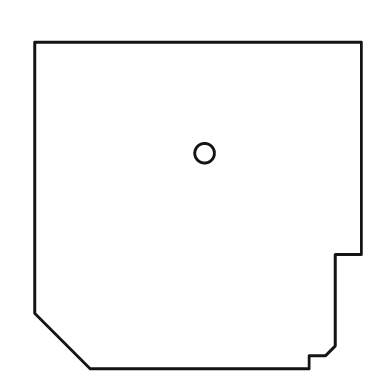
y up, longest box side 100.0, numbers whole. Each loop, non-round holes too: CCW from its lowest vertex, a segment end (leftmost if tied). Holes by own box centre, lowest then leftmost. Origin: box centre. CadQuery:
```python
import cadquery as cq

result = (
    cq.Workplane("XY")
    .moveTo(-33.0, -50.0)
    .lineTo(34.0, -50.0)
    .lineTo(34.0, -46.0)
    .lineTo(39.0, -46.0)
    .lineTo(42.0, -43.0)
    .lineTo(42.0, -15.0)
    .lineTo(50.0, -15.0)
    .lineTo(50.0, 50.0)
    .lineTo(-50.0, 50.0)
    .lineTo(-50.0, -33.0)
    .close()
    .moveTo(2.0, 16.0)
    .circle(3.0)
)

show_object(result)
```